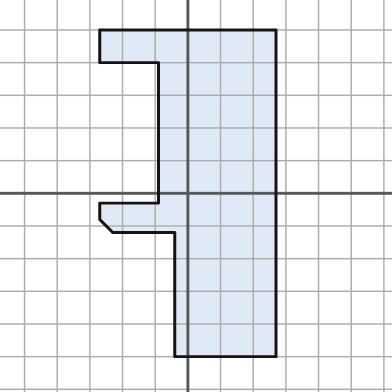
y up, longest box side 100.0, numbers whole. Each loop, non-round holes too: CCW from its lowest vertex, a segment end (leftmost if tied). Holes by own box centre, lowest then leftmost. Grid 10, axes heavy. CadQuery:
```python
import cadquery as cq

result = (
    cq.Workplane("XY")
    .moveTo(-4.0, -50.0)
    .lineTo(27.0, -50.0)
    .lineTo(27.0, 50.0)
    .lineTo(-27.0, 50.0)
    .lineTo(-27.0, 40.0)
    .lineTo(-9.0, 40.0)
    .lineTo(-9.0, -3.0)
    .lineTo(-27.0, -3.0)
    .lineTo(-27.0, -8.0)
    .lineTo(-23.0, -12.0)
    .lineTo(-4.0, -12.0)
    .close()
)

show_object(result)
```